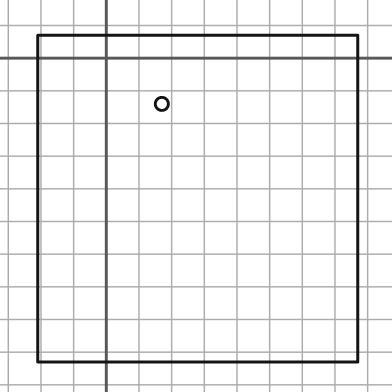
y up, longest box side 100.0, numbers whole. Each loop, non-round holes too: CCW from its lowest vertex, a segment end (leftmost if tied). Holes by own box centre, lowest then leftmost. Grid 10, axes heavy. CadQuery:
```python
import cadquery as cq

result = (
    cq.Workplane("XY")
    .moveTo(-21.0, -93.0)
    .lineTo(77.0, -93.0)
    .lineTo(77.0, 7.0)
    .lineTo(-21.0, 7.0)
    .close()
    .moveTo(17.0, -14.0)
    .circle(2.0)
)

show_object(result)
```